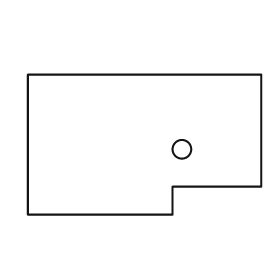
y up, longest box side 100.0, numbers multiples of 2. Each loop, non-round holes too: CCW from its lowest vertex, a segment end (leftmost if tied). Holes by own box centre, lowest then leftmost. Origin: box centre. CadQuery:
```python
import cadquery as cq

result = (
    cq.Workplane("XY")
    .moveTo(-50.0, -30.0)
    .lineTo(12.0, -30.0)
    .lineTo(12.0, -18.0)
    .lineTo(50.0, -18.0)
    .lineTo(50.0, 30.0)
    .lineTo(-50.0, 30.0)
    .close()
    .moveTo(16.0, -2.0)
    .circle(4.0)
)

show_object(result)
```